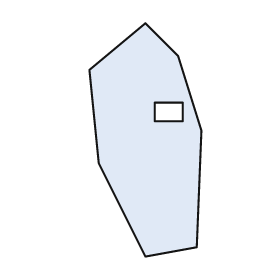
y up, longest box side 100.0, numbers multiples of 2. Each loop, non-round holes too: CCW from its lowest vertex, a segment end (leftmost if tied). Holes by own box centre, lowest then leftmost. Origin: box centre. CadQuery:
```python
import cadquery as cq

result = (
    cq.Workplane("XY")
    .moveTo(0.0, -50.0)
    .lineTo(22.0, -46.0)
    .lineTo(24.0, 4.0)
    .lineTo(14.0, 36.0)
    .lineTo(0.0, 50.0)
    .lineTo(-24.0, 30.0)
    .lineTo(-20.0, -10.0)
    .close()
    .moveTo(4.0, 8.0)
    .lineTo(16.0, 8.0)
    .lineTo(16.0, 16.0)
    .lineTo(4.0, 16.0)
    .close()
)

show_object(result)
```